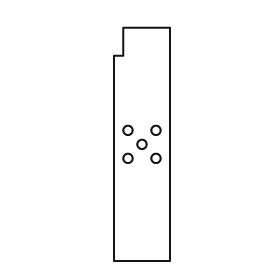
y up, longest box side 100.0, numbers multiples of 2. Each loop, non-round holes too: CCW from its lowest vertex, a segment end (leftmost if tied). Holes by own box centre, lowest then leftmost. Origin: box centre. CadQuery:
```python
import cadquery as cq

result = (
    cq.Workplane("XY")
    .moveTo(-12.0, -50.0)
    .lineTo(12.0, -50.0)
    .lineTo(12.0, 50.0)
    .lineTo(-8.0, 50.0)
    .lineTo(-8.0, 38.0)
    .lineTo(-12.0, 38.0)
    .close()
    .moveTo(-6.0, -6.0)
    .circle(2.0)
    .moveTo(6.0, -6.0)
    .circle(2.0)
    .moveTo(0.0, 0.0)
    .circle(2.0)
    .moveTo(-6.0, 6.0)
    .circle(2.0)
    .moveTo(6.0, 6.0)
    .circle(2.0)
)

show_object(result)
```